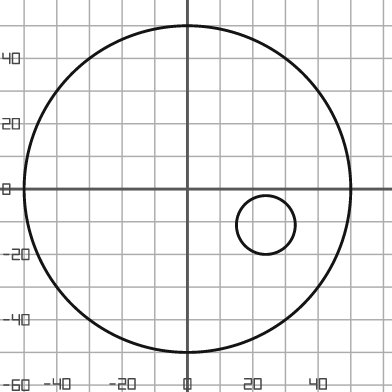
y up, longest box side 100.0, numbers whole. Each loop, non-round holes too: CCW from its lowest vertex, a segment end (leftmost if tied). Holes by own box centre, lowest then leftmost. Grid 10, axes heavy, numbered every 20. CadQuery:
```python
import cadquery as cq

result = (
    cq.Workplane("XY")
    .moveTo(0.0, 0.0)
    .circle(50.0)
    .moveTo(24.0, -11.0)
    .circle(9.0)
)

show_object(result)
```